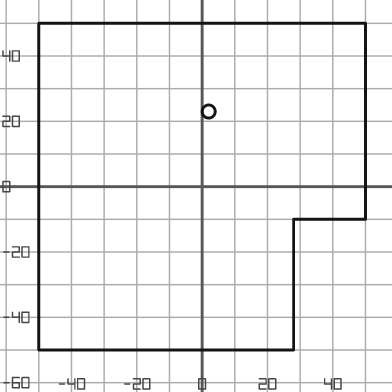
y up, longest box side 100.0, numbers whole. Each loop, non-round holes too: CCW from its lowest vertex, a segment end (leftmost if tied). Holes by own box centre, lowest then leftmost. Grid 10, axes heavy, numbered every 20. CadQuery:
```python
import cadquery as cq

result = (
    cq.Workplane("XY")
    .moveTo(-50.0, -50.0)
    .lineTo(28.0, -50.0)
    .lineTo(28.0, -10.0)
    .lineTo(50.0, -10.0)
    .lineTo(50.0, 50.0)
    .lineTo(-50.0, 50.0)
    .close()
    .moveTo(2.0, 23.0)
    .circle(2.0)
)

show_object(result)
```